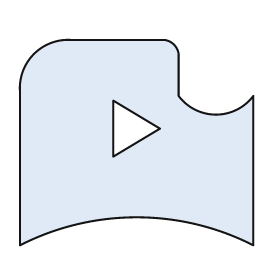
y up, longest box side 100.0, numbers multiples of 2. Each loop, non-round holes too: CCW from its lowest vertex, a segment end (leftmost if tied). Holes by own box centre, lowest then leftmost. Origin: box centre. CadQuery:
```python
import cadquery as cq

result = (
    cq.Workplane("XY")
    .moveTo(-50.0, -44.0)
    .threePointArc((0.0, -32.0), (50.0, -44.0))
    .lineTo(50.0, 20.0)
    .threePointArc((34.0, 12.0), (18.0, 20.0))
    .lineTo(18.0, 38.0)
    .threePointArc((16.0, 42.0), (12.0, 44.0))
    .lineTo(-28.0, 44.0)
    .threePointArc((-44.0, 38.0), (-50.0, 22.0))
    .close()
    .moveTo(-10.0, -6.0)
    .lineTo(10.0, 6.0)
    .lineTo(-10.0, 18.0)
    .close()
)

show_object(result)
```